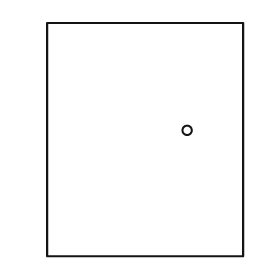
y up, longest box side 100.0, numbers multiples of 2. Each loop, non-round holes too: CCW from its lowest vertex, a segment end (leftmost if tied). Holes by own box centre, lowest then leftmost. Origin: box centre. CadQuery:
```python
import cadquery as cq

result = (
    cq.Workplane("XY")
    .moveTo(-42.0, -50.0)
    .lineTo(42.0, -50.0)
    .lineTo(42.0, 50.0)
    .lineTo(-42.0, 50.0)
    .close()
    .moveTo(18.0, 4.0)
    .circle(2.0)
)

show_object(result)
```